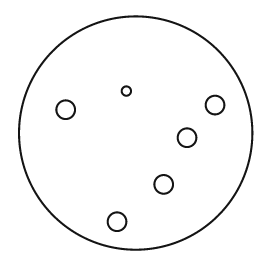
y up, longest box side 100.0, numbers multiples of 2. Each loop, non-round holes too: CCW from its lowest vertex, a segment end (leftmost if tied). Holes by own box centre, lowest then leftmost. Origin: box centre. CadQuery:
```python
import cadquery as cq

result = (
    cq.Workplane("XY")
    .moveTo(0.0, 0.0)
    .circle(50.0)
    .moveTo(-8.0, -38.0)
    .circle(4.0)
    .moveTo(12.0, -22.0)
    .circle(4.0)
    .moveTo(22.0, -2.0)
    .circle(4.0)
    .moveTo(-30.0, 10.0)
    .circle(4.0)
    .moveTo(34.0, 12.0)
    .circle(4.0)
    .moveTo(-4.0, 18.0)
    .circle(2.0)
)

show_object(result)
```